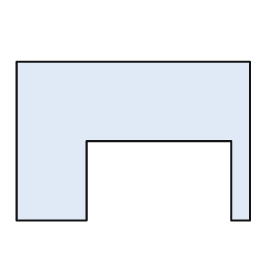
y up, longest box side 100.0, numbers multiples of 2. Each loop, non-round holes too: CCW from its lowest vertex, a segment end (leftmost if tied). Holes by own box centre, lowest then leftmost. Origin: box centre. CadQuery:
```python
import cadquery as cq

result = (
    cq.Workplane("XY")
    .moveTo(-50.0, -34.0)
    .lineTo(-20.0, -34.0)
    .lineTo(-20.0, 0.0)
    .lineTo(42.0, 0.0)
    .lineTo(42.0, -34.0)
    .lineTo(50.0, -34.0)
    .lineTo(50.0, 34.0)
    .lineTo(-50.0, 34.0)
    .close()
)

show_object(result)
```